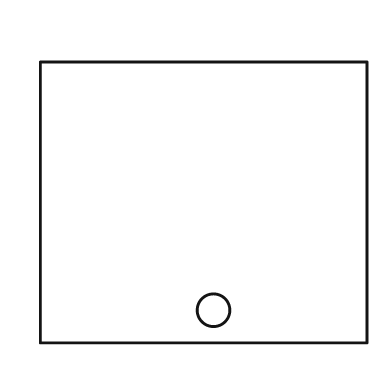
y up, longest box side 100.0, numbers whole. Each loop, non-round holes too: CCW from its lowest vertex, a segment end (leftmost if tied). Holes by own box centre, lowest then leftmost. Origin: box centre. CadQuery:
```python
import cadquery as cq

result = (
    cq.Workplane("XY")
    .moveTo(-50.0, -43.0)
    .lineTo(50.0, -43.0)
    .lineTo(50.0, 43.0)
    .lineTo(-50.0, 43.0)
    .close()
    .moveTo(3.0, -33.0)
    .circle(5.0)
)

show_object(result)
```